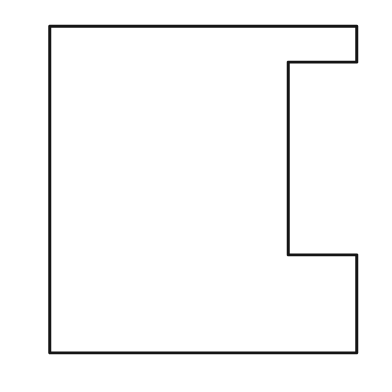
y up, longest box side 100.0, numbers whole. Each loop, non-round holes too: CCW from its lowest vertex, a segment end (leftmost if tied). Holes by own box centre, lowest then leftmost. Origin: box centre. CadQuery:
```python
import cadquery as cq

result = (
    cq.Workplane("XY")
    .moveTo(-47.0, -50.0)
    .lineTo(47.0, -50.0)
    .lineTo(47.0, -20.0)
    .lineTo(26.0, -20.0)
    .lineTo(26.0, 39.0)
    .lineTo(47.0, 39.0)
    .lineTo(47.0, 50.0)
    .lineTo(-47.0, 50.0)
    .close()
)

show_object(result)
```